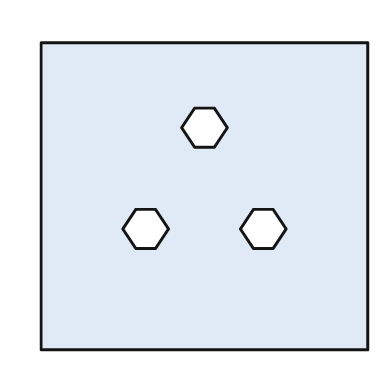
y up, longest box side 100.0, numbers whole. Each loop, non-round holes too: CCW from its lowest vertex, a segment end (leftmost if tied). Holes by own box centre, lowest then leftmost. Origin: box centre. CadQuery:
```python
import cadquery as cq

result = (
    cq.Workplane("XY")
    .moveTo(-50.0, -47.0)
    .lineTo(50.0, -47.0)
    .lineTo(50.0, 47.0)
    .lineTo(-50.0, 47.0)
    .close()
    .moveTo(-21.0, -16.0)
    .lineTo(-15.0, -16.0)
    .lineTo(-11.0, -10.0)
    .lineTo(-15.0, -4.0)
    .lineTo(-21.0, -4.0)
    .lineTo(-25.0, -10.0)
    .close()
    .moveTo(15.0, -16.0)
    .lineTo(21.0, -16.0)
    .lineTo(25.0, -10.0)
    .lineTo(21.0, -4.0)
    .lineTo(15.0, -4.0)
    .lineTo(11.0, -10.0)
    .close()
    .moveTo(-3.0, 15.0)
    .lineTo(3.0, 15.0)
    .lineTo(7.0, 21.0)
    .lineTo(3.0, 27.0)
    .lineTo(-3.0, 27.0)
    .lineTo(-7.0, 21.0)
    .close()
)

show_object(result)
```